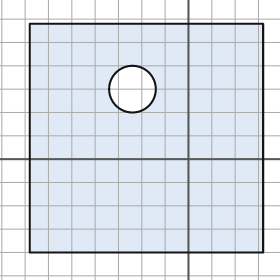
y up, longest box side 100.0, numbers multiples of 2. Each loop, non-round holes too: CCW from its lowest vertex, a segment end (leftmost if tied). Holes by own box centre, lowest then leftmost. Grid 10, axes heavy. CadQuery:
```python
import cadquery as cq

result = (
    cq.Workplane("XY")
    .moveTo(-68.0, -40.0)
    .lineTo(32.0, -40.0)
    .lineTo(32.0, 58.0)
    .lineTo(-68.0, 58.0)
    .close()
    .moveTo(-24.0, 30.0)
    .circle(10.0)
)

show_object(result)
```